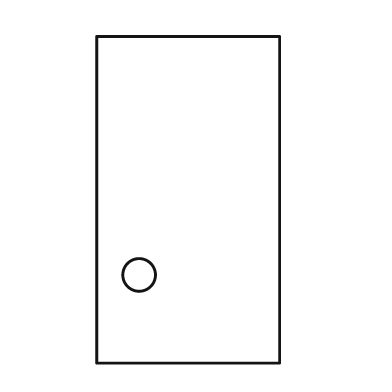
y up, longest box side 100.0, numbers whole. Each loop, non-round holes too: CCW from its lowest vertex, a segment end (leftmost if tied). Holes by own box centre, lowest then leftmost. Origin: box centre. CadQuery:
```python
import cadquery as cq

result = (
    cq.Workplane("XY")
    .moveTo(-28.0, -50.0)
    .lineTo(28.0, -50.0)
    .lineTo(28.0, 50.0)
    .lineTo(-28.0, 50.0)
    .close()
    .moveTo(-15.0, -23.0)
    .circle(5.0)
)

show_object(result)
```